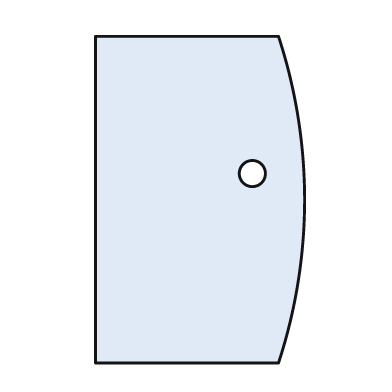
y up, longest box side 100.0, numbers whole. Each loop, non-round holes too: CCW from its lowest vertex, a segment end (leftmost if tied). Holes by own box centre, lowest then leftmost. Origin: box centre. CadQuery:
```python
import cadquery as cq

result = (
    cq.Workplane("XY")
    .moveTo(-32.0, -50.0)
    .lineTo(24.0, -50.0)
    .threePointArc((32.0, 0.0), (24.0, 50.0))
    .lineTo(-32.0, 50.0)
    .close()
    .moveTo(16.0, 8.0)
    .circle(4.0)
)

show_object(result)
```